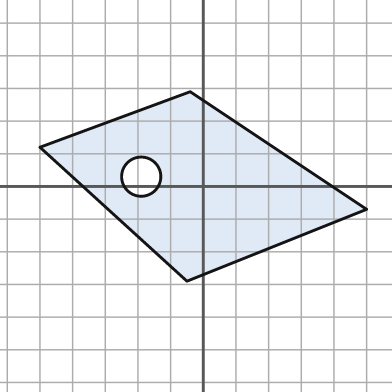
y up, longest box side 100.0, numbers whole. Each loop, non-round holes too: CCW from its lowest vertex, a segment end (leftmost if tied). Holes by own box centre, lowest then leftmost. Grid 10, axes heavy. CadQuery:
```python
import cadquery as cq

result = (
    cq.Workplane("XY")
    .moveTo(-5.0, -29.0)
    .lineTo(50.0, -7.0)
    .lineTo(-4.0, 29.0)
    .lineTo(-50.0, 12.0)
    .close()
    .moveTo(-19.0, 3.0)
    .circle(6.0)
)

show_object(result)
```